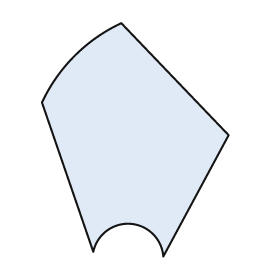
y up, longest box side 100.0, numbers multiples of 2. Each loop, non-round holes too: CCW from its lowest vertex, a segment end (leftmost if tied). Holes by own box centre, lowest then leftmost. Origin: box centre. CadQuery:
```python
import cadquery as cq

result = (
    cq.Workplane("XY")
    .moveTo(12.0, -50.0)
    .lineTo(40.0, 2.0)
    .lineTo(-6.0, 50.0)
    .threePointArc((-26.0, 36.0), (-40.0, 16.0))
    .lineTo(-18.0, -48.0)
    .threePointArc((-2.0, -36.0), (12.0, -50.0))
    .close()
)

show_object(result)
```